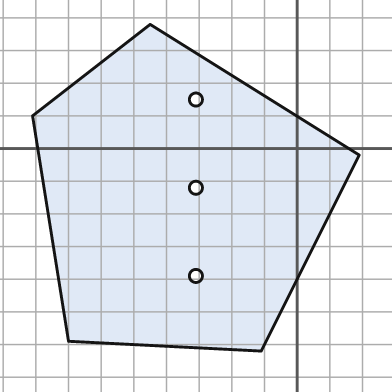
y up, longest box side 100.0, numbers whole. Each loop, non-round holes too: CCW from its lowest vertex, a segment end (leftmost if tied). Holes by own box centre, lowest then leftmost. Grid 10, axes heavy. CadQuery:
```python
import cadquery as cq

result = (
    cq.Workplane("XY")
    .moveTo(-11.0, -62.0)
    .lineTo(19.0, -2.0)
    .lineTo(-45.0, 38.0)
    .lineTo(-81.0, 10.0)
    .lineTo(-70.0, -59.0)
    .close()
    .moveTo(-31.0, -39.0)
    .circle(2.0)
    .moveTo(-31.0, -12.0)
    .circle(2.0)
    .moveTo(-31.0, 15.0)
    .circle(2.0)
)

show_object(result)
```